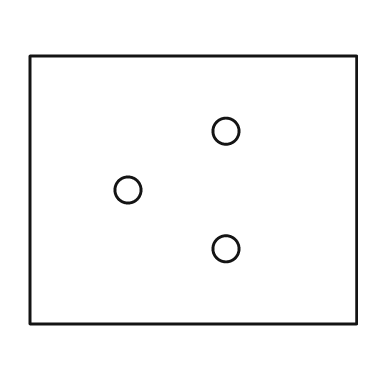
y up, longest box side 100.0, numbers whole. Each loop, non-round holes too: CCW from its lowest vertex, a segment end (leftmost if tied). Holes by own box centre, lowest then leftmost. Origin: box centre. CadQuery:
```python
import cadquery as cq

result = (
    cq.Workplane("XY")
    .moveTo(-50.0, -41.0)
    .lineTo(50.0, -41.0)
    .lineTo(50.0, 41.0)
    .lineTo(-50.0, 41.0)
    .close()
    .moveTo(10.0, -18.0)
    .circle(4.0)
    .moveTo(-20.0, 0.0)
    .circle(4.0)
    .moveTo(10.0, 18.0)
    .circle(4.0)
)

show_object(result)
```